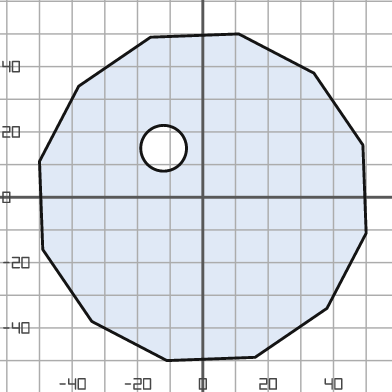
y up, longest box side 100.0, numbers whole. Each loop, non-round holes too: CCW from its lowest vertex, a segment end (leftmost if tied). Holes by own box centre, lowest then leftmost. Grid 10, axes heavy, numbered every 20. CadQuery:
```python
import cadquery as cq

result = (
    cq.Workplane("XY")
    .moveTo(-11.0, -50.0)
    .lineTo(16.0, -49.0)
    .lineTo(38.0, -34.0)
    .lineTo(50.0, -11.0)
    .lineTo(49.0, 16.0)
    .lineTo(34.0, 38.0)
    .lineTo(11.0, 50.0)
    .lineTo(-16.0, 49.0)
    .lineTo(-38.0, 34.0)
    .lineTo(-50.0, 11.0)
    .lineTo(-49.0, -16.0)
    .lineTo(-34.0, -38.0)
    .close()
    .moveTo(-12.0, 15.0)
    .circle(7.0)
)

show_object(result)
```